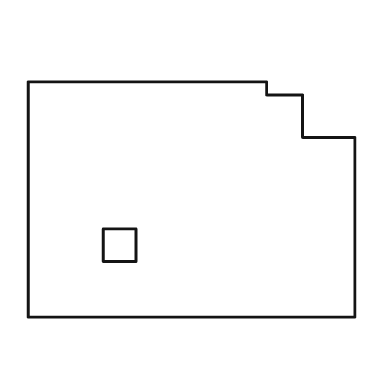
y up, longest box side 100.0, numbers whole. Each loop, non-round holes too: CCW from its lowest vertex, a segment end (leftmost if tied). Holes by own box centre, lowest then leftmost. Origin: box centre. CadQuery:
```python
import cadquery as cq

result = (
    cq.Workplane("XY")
    .moveTo(-50.0, -36.0)
    .lineTo(50.0, -36.0)
    .lineTo(50.0, 19.0)
    .lineTo(34.0, 19.0)
    .lineTo(34.0, 32.0)
    .lineTo(23.0, 32.0)
    .lineTo(23.0, 36.0)
    .lineTo(-50.0, 36.0)
    .close()
    .moveTo(-27.0, -19.0)
    .lineTo(-17.0, -19.0)
    .lineTo(-17.0, -9.0)
    .lineTo(-27.0, -9.0)
    .close()
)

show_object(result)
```